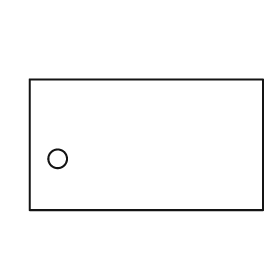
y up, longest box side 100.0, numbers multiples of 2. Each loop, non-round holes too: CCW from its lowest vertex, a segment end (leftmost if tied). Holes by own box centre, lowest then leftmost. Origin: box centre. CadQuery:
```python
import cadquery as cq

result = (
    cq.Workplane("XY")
    .moveTo(-50.0, -28.0)
    .lineTo(50.0, -28.0)
    .lineTo(50.0, 28.0)
    .lineTo(-50.0, 28.0)
    .close()
    .moveTo(-38.0, -6.0)
    .circle(4.0)
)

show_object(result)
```